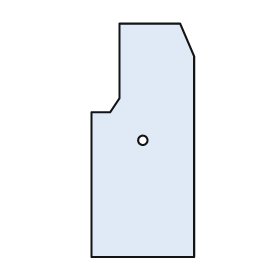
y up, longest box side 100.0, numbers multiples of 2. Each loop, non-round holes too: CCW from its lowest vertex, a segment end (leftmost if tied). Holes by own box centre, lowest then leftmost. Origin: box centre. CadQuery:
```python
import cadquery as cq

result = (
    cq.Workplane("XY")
    .moveTo(-22.0, -50.0)
    .lineTo(22.0, -50.0)
    .lineTo(22.0, 36.0)
    .lineTo(16.0, 50.0)
    .lineTo(-10.0, 50.0)
    .lineTo(-10.0, 18.0)
    .lineTo(-14.0, 12.0)
    .lineTo(-22.0, 12.0)
    .close()
    .moveTo(0.0, 0.0)
    .circle(2.0)
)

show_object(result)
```